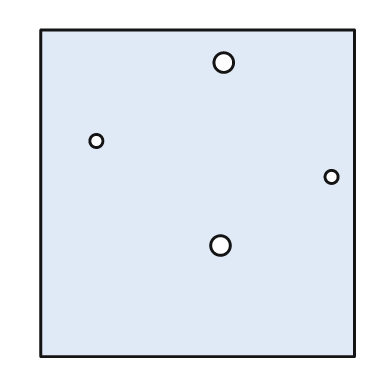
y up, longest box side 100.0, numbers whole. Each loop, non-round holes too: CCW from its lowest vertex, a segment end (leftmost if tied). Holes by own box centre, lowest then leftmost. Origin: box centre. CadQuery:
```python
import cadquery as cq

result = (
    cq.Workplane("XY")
    .moveTo(-48.0, -50.0)
    .lineTo(48.0, -50.0)
    .lineTo(48.0, 50.0)
    .lineTo(-48.0, 50.0)
    .close()
    .moveTo(7.0, -16.0)
    .circle(3.0)
    .moveTo(41.0, 5.0)
    .circle(2.0)
    .moveTo(-31.0, 16.0)
    .circle(2.0)
    .moveTo(8.0, 40.0)
    .circle(3.0)
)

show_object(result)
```